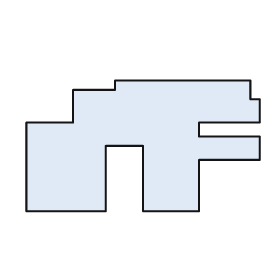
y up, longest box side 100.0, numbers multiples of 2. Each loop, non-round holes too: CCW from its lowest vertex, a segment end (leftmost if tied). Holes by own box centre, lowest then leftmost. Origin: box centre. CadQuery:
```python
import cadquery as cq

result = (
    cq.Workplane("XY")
    .moveTo(-50.0, -28.0)
    .lineTo(-16.0, -28.0)
    .lineTo(-16.0, 0.0)
    .lineTo(0.0, 0.0)
    .lineTo(0.0, -28.0)
    .lineTo(24.0, -28.0)
    .lineTo(24.0, -6.0)
    .lineTo(50.0, -6.0)
    .lineTo(50.0, 4.0)
    .lineTo(24.0, 4.0)
    .lineTo(24.0, 10.0)
    .lineTo(50.0, 10.0)
    .lineTo(50.0, 20.0)
    .lineTo(46.0, 20.0)
    .lineTo(46.0, 28.0)
    .lineTo(-12.0, 28.0)
    .lineTo(-12.0, 24.0)
    .lineTo(-30.0, 24.0)
    .lineTo(-30.0, 10.0)
    .lineTo(-50.0, 10.0)
    .close()
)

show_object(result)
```